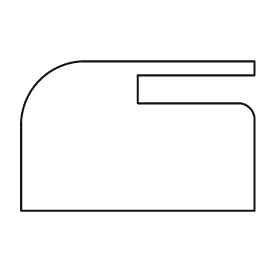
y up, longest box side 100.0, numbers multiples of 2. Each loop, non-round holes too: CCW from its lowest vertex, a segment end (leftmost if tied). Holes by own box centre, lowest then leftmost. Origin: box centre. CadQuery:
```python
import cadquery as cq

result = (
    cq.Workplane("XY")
    .moveTo(-50.0, -32.0)
    .lineTo(50.0, -32.0)
    .lineTo(50.0, 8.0)
    .threePointArc((48.0, 12.0), (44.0, 14.0))
    .lineTo(0.0, 14.0)
    .lineTo(0.0, 26.0)
    .lineTo(50.0, 26.0)
    .lineTo(50.0, 32.0)
    .lineTo(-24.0, 32.0)
    .threePointArc((-42.0, 24.0), (-50.0, 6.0))
    .close()
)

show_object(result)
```